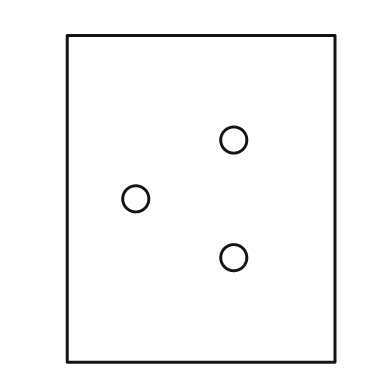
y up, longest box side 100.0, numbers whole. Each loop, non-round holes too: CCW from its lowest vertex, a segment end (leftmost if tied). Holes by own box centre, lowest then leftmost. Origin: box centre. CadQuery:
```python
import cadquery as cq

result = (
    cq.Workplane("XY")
    .moveTo(-41.0, -50.0)
    .lineTo(41.0, -50.0)
    .lineTo(41.0, 50.0)
    .lineTo(-41.0, 50.0)
    .close()
    .moveTo(10.0, -18.0)
    .circle(4.0)
    .moveTo(-20.0, 0.0)
    .circle(4.0)
    .moveTo(10.0, 18.0)
    .circle(4.0)
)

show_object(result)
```